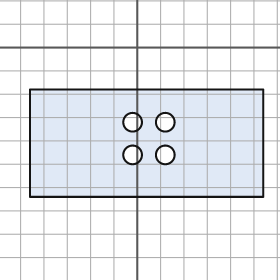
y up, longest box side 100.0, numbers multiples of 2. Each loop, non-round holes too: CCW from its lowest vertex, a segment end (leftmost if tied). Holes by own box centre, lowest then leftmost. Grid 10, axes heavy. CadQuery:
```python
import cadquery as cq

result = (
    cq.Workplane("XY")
    .moveTo(-46.0, -64.0)
    .lineTo(54.0, -64.0)
    .lineTo(54.0, -18.0)
    .lineTo(-46.0, -18.0)
    .close()
    .moveTo(-2.0, -46.0)
    .circle(4.0)
    .moveTo(12.0, -46.0)
    .circle(4.0)
    .moveTo(-2.0, -32.0)
    .circle(4.0)
    .moveTo(12.0, -32.0)
    .circle(4.0)
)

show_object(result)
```